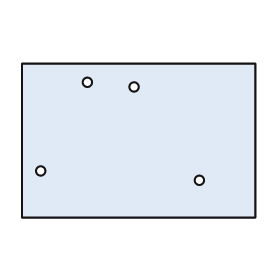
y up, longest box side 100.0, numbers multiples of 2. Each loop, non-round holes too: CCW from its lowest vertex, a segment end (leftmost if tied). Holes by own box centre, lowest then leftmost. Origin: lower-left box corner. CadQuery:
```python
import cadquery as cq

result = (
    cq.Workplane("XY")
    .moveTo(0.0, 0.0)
    .lineTo(100.0, 0.0)
    .lineTo(100.0, 66.0)
    .lineTo(0.0, 66.0)
    .close()
    .moveTo(76.0, 16.0)
    .circle(2.0)
    .moveTo(8.0, 20.0)
    .circle(2.0)
    .moveTo(48.0, 56.0)
    .circle(2.0)
    .moveTo(28.0, 58.0)
    .circle(2.0)
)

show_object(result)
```